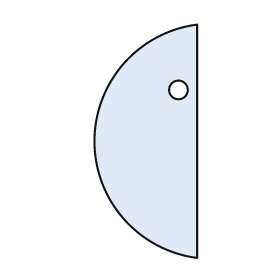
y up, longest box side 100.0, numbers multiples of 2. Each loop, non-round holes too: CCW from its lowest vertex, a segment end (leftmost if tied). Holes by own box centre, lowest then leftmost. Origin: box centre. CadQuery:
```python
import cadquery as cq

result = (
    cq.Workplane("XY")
    .moveTo(22.0, -50.0)
    .lineTo(22.0, 50.0)
    .threePointArc((-22.0, 0.0), (22.0, -50.0))
    .close()
    .moveTo(14.0, 22.0)
    .circle(4.0)
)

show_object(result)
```